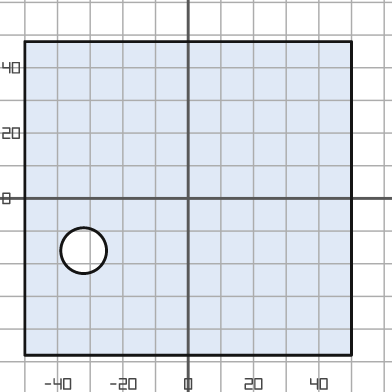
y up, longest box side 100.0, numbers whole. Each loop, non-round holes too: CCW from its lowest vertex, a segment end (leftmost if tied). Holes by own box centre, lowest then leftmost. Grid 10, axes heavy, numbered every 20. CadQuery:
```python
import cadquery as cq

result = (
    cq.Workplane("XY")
    .moveTo(-50.0, -48.0)
    .lineTo(50.0, -48.0)
    .lineTo(50.0, 48.0)
    .lineTo(-50.0, 48.0)
    .close()
    .moveTo(-32.0, -16.0)
    .circle(7.0)
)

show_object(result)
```